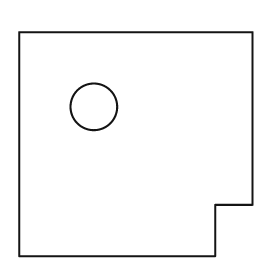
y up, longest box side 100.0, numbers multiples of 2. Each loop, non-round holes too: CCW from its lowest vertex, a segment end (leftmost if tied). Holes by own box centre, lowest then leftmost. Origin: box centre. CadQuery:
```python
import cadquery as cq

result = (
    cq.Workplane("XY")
    .moveTo(-50.0, -48.0)
    .lineTo(34.0, -48.0)
    .lineTo(34.0, -26.0)
    .lineTo(50.0, -26.0)
    .lineTo(50.0, 48.0)
    .lineTo(-50.0, 48.0)
    .close()
    .moveTo(-18.0, 16.0)
    .circle(10.0)
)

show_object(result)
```